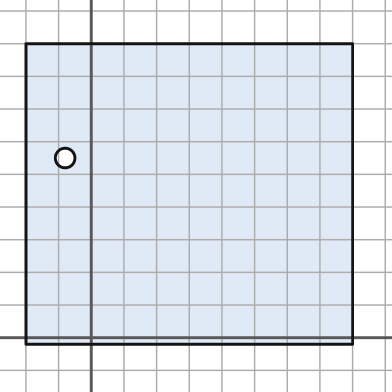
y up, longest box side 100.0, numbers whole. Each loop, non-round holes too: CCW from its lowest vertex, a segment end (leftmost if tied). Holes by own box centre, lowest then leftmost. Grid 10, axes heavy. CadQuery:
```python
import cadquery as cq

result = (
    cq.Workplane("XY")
    .moveTo(-20.0, -2.0)
    .lineTo(80.0, -2.0)
    .lineTo(80.0, 90.0)
    .lineTo(-20.0, 90.0)
    .close()
    .moveTo(-8.0, 55.0)
    .circle(3.0)
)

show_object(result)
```